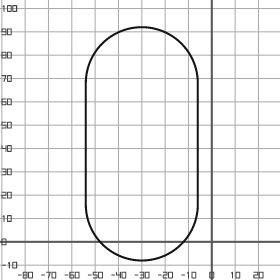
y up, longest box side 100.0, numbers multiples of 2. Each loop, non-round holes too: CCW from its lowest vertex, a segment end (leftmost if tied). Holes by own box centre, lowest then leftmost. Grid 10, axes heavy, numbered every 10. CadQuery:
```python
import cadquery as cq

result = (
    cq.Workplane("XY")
    .moveTo(-54.0, 16.0)
    .threePointArc((-30.0, -8.0), (-6.0, 16.0))
    .lineTo(-6.0, 68.0)
    .threePointArc((-30.0, 92.0), (-54.0, 68.0))
    .close()
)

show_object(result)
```